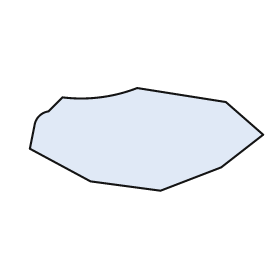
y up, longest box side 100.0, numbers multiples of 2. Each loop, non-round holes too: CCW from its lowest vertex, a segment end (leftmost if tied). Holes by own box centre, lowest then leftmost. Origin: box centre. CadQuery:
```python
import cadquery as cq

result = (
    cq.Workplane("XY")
    .moveTo(6.0, -22.0)
    .lineTo(32.0, -12.0)
    .lineTo(50.0, 2.0)
    .lineTo(34.0, 16.0)
    .lineTo(-4.0, 22.0)
    .threePointArc((-20.0, 18.0), (-36.0, 18.0))
    .lineTo(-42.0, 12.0)
    .threePointArc((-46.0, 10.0), (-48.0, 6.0))
    .lineTo(-50.0, -4.0)
    .lineTo(-24.0, -18.0)
    .close()
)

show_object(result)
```